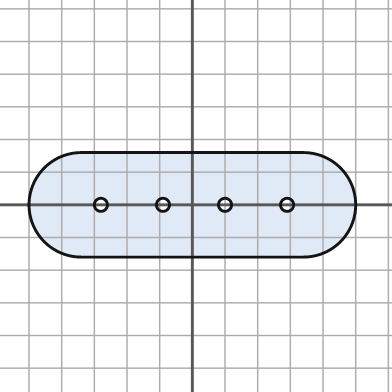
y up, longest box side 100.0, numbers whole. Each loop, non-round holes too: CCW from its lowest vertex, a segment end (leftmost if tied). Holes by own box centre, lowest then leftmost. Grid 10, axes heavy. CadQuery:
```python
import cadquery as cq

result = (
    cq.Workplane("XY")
    .moveTo(-34.0, -16.0)
    .lineTo(34.0, -16.0)
    .threePointArc((50.0, 0.0), (34.0, 16.0))
    .lineTo(-34.0, 16.0)
    .threePointArc((-50.0, 0.0), (-34.0, -16.0))
    .close()
    .moveTo(-28.0, 0.0)
    .circle(2.0)
    .moveTo(-9.0, 0.0)
    .circle(2.0)
    .moveTo(10.0, 0.0)
    .circle(2.0)
    .moveTo(29.0, 0.0)
    .circle(2.0)
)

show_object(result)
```